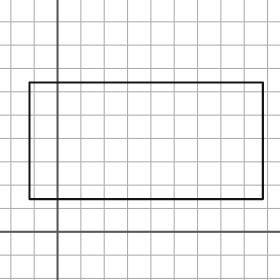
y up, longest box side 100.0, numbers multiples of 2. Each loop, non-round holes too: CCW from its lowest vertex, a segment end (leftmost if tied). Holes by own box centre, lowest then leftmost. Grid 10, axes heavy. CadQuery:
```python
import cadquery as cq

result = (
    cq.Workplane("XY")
    .moveTo(-12.0, 14.0)
    .lineTo(88.0, 14.0)
    .lineTo(88.0, 64.0)
    .lineTo(-12.0, 64.0)
    .close()
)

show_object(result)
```